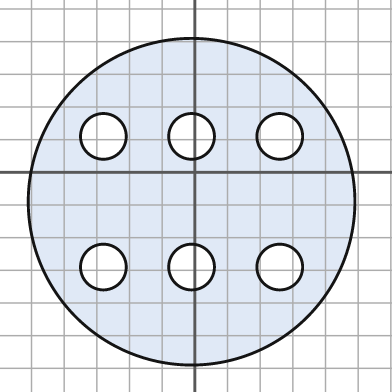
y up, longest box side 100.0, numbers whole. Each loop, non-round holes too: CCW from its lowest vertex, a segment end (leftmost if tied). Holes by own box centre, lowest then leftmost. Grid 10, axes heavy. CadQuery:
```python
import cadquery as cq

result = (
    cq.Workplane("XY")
    .moveTo(-1.0, -9.0)
    .circle(50.0)
    .moveTo(-28.0, -29.0)
    .circle(7.0)
    .moveTo(-1.0, -29.0)
    .circle(7.0)
    .moveTo(26.0, -29.0)
    .circle(7.0)
    .moveTo(-28.0, 11.0)
    .circle(7.0)
    .moveTo(-1.0, 11.0)
    .circle(7.0)
    .moveTo(26.0, 11.0)
    .circle(7.0)
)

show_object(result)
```